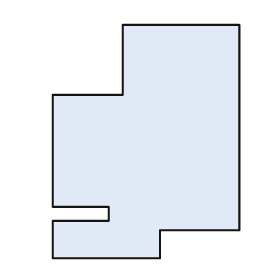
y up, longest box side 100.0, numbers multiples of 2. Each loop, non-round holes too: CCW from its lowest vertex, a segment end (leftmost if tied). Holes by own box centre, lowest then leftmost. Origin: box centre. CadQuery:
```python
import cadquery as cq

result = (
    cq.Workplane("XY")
    .moveTo(-40.0, -50.0)
    .lineTo(6.0, -50.0)
    .lineTo(6.0, -38.0)
    .lineTo(40.0, -38.0)
    .lineTo(40.0, 50.0)
    .lineTo(-10.0, 50.0)
    .lineTo(-10.0, 20.0)
    .lineTo(-40.0, 20.0)
    .lineTo(-40.0, -28.0)
    .lineTo(-16.0, -28.0)
    .lineTo(-16.0, -34.0)
    .lineTo(-40.0, -34.0)
    .close()
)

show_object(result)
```